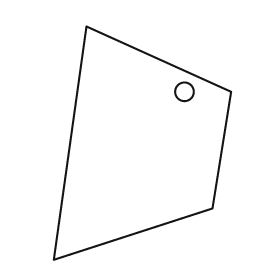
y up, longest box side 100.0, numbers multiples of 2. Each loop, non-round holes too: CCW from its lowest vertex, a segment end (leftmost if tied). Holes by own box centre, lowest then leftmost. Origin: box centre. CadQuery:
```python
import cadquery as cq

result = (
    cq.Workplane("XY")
    .moveTo(-38.0, -50.0)
    .lineTo(30.0, -28.0)
    .lineTo(38.0, 22.0)
    .lineTo(-24.0, 50.0)
    .close()
    .moveTo(18.0, 22.0)
    .circle(4.0)
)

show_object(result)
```